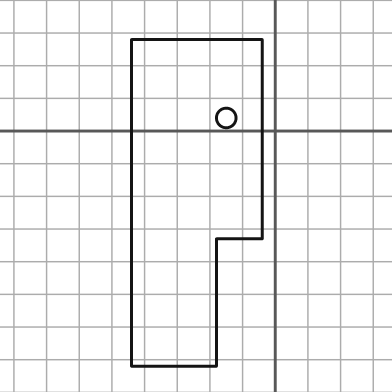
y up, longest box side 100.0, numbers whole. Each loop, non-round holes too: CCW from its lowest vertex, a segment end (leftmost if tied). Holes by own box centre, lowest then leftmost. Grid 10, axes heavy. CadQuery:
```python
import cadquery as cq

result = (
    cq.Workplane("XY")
    .moveTo(-44.0, -72.0)
    .lineTo(-18.0, -72.0)
    .lineTo(-18.0, -33.0)
    .lineTo(-4.0, -33.0)
    .lineTo(-4.0, 28.0)
    .lineTo(-44.0, 28.0)
    .close()
    .moveTo(-15.0, 4.0)
    .circle(3.0)
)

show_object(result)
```